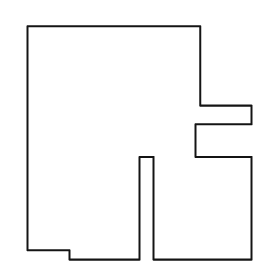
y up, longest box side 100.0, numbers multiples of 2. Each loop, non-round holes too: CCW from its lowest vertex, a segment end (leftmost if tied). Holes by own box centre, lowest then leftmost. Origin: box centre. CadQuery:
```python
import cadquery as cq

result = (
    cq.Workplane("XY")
    .moveTo(-30.0, -50.0)
    .lineTo(0.0, -50.0)
    .lineTo(0.0, -6.0)
    .lineTo(6.0, -6.0)
    .lineTo(6.0, -50.0)
    .lineTo(48.0, -50.0)
    .lineTo(48.0, -6.0)
    .lineTo(24.0, -6.0)
    .lineTo(24.0, 8.0)
    .lineTo(48.0, 8.0)
    .lineTo(48.0, 16.0)
    .lineTo(26.0, 16.0)
    .lineTo(26.0, 50.0)
    .lineTo(-48.0, 50.0)
    .lineTo(-48.0, -46.0)
    .lineTo(-30.0, -46.0)
    .close()
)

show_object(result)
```